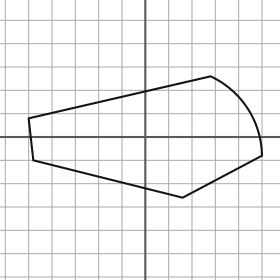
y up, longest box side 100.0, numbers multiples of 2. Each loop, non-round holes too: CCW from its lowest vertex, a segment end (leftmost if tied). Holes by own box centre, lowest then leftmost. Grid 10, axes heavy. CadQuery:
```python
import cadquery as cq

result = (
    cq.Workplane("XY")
    .moveTo(16.0, -26.0)
    .lineTo(50.0, -8.0)
    .threePointArc((44.0, 12.0), (28.0, 26.0))
    .lineTo(-50.0, 8.0)
    .lineTo(-48.0, -10.0)
    .close()
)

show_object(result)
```